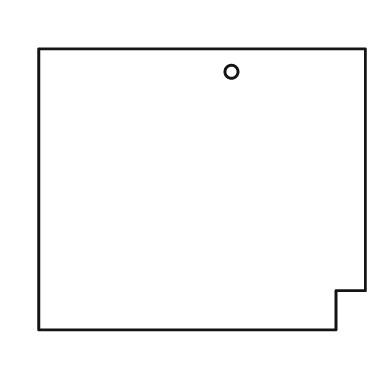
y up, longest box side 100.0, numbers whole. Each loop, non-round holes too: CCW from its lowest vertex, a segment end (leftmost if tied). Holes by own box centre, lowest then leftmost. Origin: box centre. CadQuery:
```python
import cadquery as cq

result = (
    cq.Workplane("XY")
    .moveTo(-50.0, -43.0)
    .lineTo(41.0, -43.0)
    .lineTo(41.0, -31.0)
    .lineTo(50.0, -31.0)
    .lineTo(50.0, 43.0)
    .lineTo(-50.0, 43.0)
    .close()
    .moveTo(9.0, 36.0)
    .circle(2.0)
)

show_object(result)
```